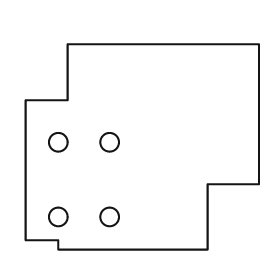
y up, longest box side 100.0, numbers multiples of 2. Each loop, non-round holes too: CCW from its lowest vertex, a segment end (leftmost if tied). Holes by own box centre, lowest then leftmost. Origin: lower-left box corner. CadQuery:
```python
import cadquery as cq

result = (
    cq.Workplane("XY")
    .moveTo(14.0, 0.0)
    .lineTo(78.0, 0.0)
    .lineTo(78.0, 28.0)
    .lineTo(100.0, 28.0)
    .lineTo(100.0, 88.0)
    .lineTo(18.0, 88.0)
    .lineTo(18.0, 64.0)
    .lineTo(0.0, 64.0)
    .lineTo(0.0, 4.0)
    .lineTo(14.0, 4.0)
    .close()
    .moveTo(14.0, 14.0)
    .circle(4.0)
    .moveTo(36.0, 14.0)
    .circle(4.0)
    .moveTo(14.0, 46.0)
    .circle(4.0)
    .moveTo(36.0, 46.0)
    .circle(4.0)
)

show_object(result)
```